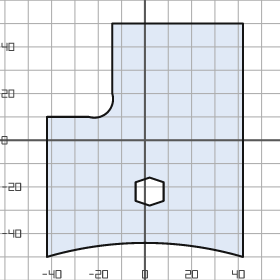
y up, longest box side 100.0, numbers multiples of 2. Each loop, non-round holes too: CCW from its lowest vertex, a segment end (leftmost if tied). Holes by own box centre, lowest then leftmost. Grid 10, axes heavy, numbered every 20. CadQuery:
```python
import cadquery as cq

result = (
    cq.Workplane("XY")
    .moveTo(-42.0, -50.0)
    .threePointArc((0.0, -44.0), (42.0, -50.0))
    .lineTo(42.0, 50.0)
    .lineTo(-14.0, 50.0)
    .lineTo(-14.0, 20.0)
    .threePointArc((-16.0, 12.0), (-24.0, 10.0))
    .lineTo(-42.0, 10.0)
    .close()
    .moveTo(2.0, -28.0)
    .lineTo(8.0, -26.0)
    .lineTo(8.0, -18.0)
    .lineTo(2.0, -16.0)
    .lineTo(-4.0, -18.0)
    .lineTo(-4.0, -26.0)
    .close()
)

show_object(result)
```